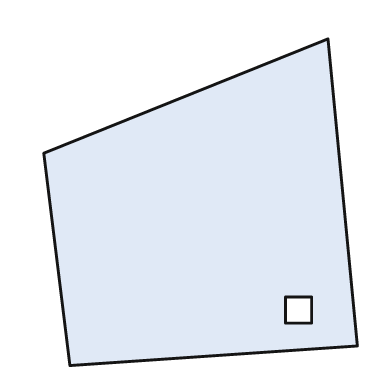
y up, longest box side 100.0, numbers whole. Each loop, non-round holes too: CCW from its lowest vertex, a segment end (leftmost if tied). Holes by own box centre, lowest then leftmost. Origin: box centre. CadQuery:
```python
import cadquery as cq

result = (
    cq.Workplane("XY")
    .moveTo(-40.0, -50.0)
    .lineTo(48.0, -44.0)
    .lineTo(39.0, 50.0)
    .lineTo(-48.0, 15.0)
    .close()
    .moveTo(26.0, -37.0)
    .lineTo(34.0, -37.0)
    .lineTo(34.0, -29.0)
    .lineTo(26.0, -29.0)
    .close()
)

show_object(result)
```